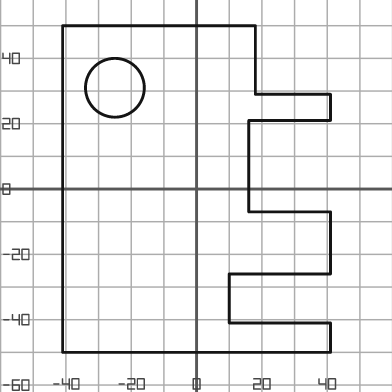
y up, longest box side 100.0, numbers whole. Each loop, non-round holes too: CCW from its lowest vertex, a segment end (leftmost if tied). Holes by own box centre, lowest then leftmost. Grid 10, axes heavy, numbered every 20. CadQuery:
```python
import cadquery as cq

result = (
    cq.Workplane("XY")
    .moveTo(-41.0, -50.0)
    .lineTo(41.0, -50.0)
    .lineTo(41.0, -41.0)
    .lineTo(10.0, -41.0)
    .lineTo(10.0, -26.0)
    .lineTo(41.0, -26.0)
    .lineTo(41.0, -7.0)
    .lineTo(16.0, -7.0)
    .lineTo(16.0, 21.0)
    .lineTo(41.0, 21.0)
    .lineTo(41.0, 29.0)
    .lineTo(18.0, 29.0)
    .lineTo(18.0, 50.0)
    .lineTo(-41.0, 50.0)
    .close()
    .moveTo(-25.0, 31.0)
    .circle(9.0)
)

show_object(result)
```